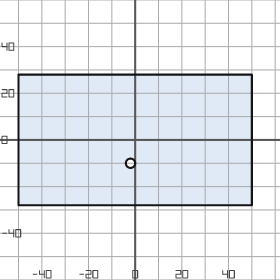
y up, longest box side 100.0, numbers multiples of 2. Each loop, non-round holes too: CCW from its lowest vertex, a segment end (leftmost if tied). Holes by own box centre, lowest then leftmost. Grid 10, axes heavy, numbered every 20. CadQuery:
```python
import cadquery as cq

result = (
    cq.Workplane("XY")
    .moveTo(-50.0, -28.0)
    .lineTo(50.0, -28.0)
    .lineTo(50.0, 28.0)
    .lineTo(-50.0, 28.0)
    .close()
    .moveTo(-2.0, -10.0)
    .circle(2.0)
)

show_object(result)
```